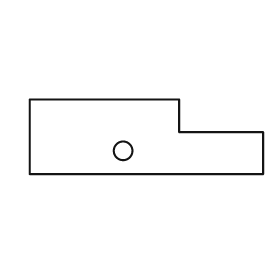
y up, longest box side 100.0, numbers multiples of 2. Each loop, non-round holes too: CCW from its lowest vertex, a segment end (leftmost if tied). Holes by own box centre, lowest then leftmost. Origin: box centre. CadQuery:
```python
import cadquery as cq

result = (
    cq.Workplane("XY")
    .moveTo(-50.0, -16.0)
    .lineTo(50.0, -16.0)
    .lineTo(50.0, 2.0)
    .lineTo(14.0, 2.0)
    .lineTo(14.0, 16.0)
    .lineTo(-50.0, 16.0)
    .close()
    .moveTo(-10.0, -6.0)
    .circle(4.0)
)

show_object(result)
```